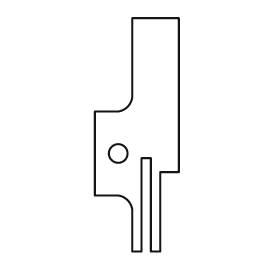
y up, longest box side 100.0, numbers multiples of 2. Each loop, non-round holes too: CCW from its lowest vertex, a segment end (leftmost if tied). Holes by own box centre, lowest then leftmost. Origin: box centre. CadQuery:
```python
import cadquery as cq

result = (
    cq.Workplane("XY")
    .moveTo(-2.0, -50.0)
    .lineTo(2.0, -50.0)
    .lineTo(2.0, -10.0)
    .lineTo(6.0, -10.0)
    .lineTo(6.0, -50.0)
    .lineTo(10.0, -50.0)
    .lineTo(10.0, -16.0)
    .lineTo(18.0, -16.0)
    .lineTo(18.0, 50.0)
    .lineTo(-2.0, 50.0)
    .lineTo(-2.0, 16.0)
    .threePointArc((-4.0, 12.0), (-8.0, 10.0))
    .lineTo(-18.0, 10.0)
    .lineTo(-18.0, -26.0)
    .lineTo(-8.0, -26.0)
    .threePointArc((-4.0, -28.0), (-2.0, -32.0))
    .close()
    .moveTo(-8.0, -8.0)
    .circle(4.0)
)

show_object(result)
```